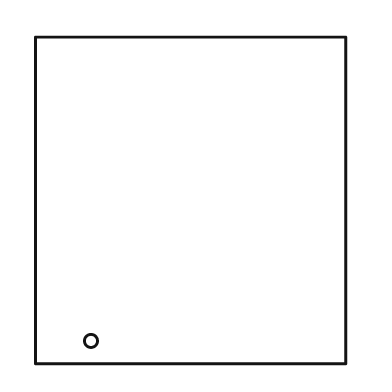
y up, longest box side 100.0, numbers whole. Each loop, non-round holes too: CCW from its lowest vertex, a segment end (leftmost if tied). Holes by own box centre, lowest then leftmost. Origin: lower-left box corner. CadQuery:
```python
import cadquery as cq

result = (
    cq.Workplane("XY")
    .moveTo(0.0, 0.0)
    .lineTo(95.0, 0.0)
    .lineTo(95.0, 100.0)
    .lineTo(0.0, 100.0)
    .close()
    .moveTo(17.0, 7.0)
    .circle(2.0)
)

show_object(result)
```